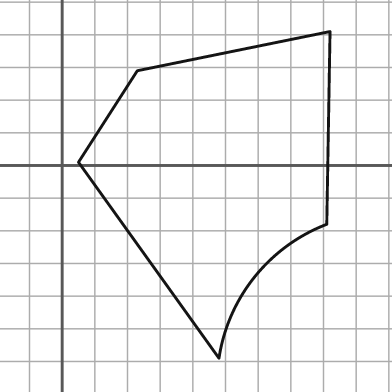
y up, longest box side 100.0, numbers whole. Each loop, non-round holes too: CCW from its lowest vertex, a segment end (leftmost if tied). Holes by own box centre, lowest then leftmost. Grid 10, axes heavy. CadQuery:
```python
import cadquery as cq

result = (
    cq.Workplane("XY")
    .moveTo(48.0, -59.0)
    .threePointArc((59.0, -34.0), (81.0, -18.0))
    .lineTo(82.0, 41.0)
    .lineTo(23.0, 29.0)
    .lineTo(5.0, 1.0)
    .close()
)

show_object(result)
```